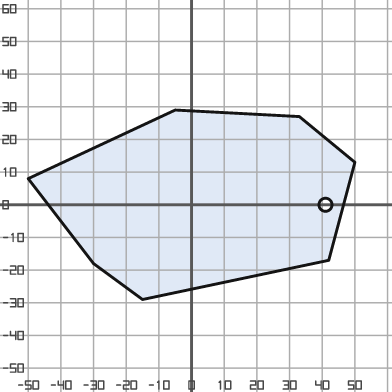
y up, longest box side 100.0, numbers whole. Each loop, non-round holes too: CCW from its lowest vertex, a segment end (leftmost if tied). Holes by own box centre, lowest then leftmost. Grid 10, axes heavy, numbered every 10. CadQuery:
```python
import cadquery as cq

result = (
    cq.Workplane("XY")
    .moveTo(-15.0, -29.0)
    .lineTo(42.0, -17.0)
    .lineTo(50.0, 13.0)
    .lineTo(33.0, 27.0)
    .lineTo(-5.0, 29.0)
    .lineTo(-50.0, 8.0)
    .lineTo(-30.0, -18.0)
    .close()
    .moveTo(41.0, 0.0)
    .circle(2.0)
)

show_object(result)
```